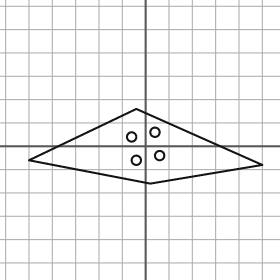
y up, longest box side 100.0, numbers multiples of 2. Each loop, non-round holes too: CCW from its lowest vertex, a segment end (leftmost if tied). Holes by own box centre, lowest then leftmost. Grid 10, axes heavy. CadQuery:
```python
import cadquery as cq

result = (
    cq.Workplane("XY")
    .moveTo(2.0, -16.0)
    .lineTo(50.0, -8.0)
    .lineTo(-4.0, 16.0)
    .lineTo(-50.0, -6.0)
    .close()
    .moveTo(-4.0, -6.0)
    .circle(2.0)
    .moveTo(6.0, -4.0)
    .circle(2.0)
    .moveTo(-6.0, 4.0)
    .circle(2.0)
    .moveTo(4.0, 6.0)
    .circle(2.0)
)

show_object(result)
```